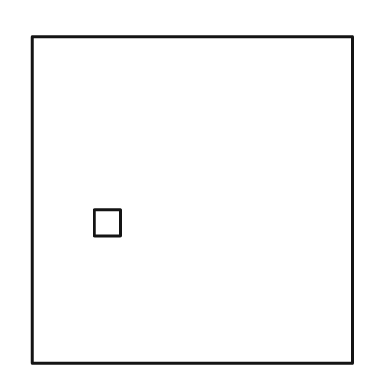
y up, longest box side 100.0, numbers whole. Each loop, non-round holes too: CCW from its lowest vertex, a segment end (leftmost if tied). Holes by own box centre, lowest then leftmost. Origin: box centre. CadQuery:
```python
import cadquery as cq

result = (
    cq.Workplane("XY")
    .moveTo(-49.0, -50.0)
    .lineTo(49.0, -50.0)
    .lineTo(49.0, 50.0)
    .lineTo(-49.0, 50.0)
    .close()
    .moveTo(-30.0, -11.0)
    .lineTo(-22.0, -11.0)
    .lineTo(-22.0, -3.0)
    .lineTo(-30.0, -3.0)
    .close()
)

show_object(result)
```